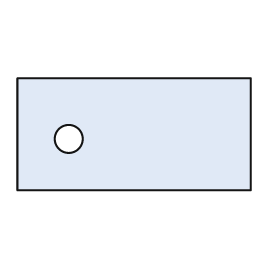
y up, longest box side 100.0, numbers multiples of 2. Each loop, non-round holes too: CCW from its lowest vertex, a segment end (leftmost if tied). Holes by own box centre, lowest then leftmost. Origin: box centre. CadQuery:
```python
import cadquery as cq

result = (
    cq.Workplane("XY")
    .moveTo(-50.0, -24.0)
    .lineTo(50.0, -24.0)
    .lineTo(50.0, 24.0)
    .lineTo(-50.0, 24.0)
    .close()
    .moveTo(-28.0, -2.0)
    .circle(6.0)
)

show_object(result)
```